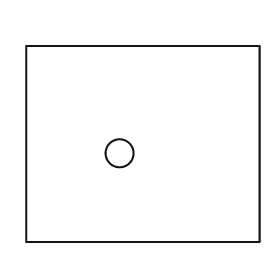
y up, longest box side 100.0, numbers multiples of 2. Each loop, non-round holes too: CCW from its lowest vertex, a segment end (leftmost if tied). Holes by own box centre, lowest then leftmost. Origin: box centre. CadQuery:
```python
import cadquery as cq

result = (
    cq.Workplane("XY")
    .moveTo(-50.0, -42.0)
    .lineTo(50.0, -42.0)
    .lineTo(50.0, 42.0)
    .lineTo(-50.0, 42.0)
    .close()
    .moveTo(-10.0, -4.0)
    .circle(6.0)
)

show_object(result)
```